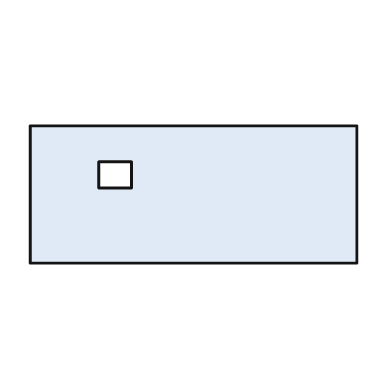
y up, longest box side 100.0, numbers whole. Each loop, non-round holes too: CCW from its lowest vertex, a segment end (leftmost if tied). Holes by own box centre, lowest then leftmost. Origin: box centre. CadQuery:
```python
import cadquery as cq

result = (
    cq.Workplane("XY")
    .moveTo(-50.0, -21.0)
    .lineTo(50.0, -21.0)
    .lineTo(50.0, 21.0)
    .lineTo(-50.0, 21.0)
    .close()
    .moveTo(-29.0, 2.0)
    .lineTo(-19.0, 2.0)
    .lineTo(-19.0, 10.0)
    .lineTo(-29.0, 10.0)
    .close()
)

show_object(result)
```